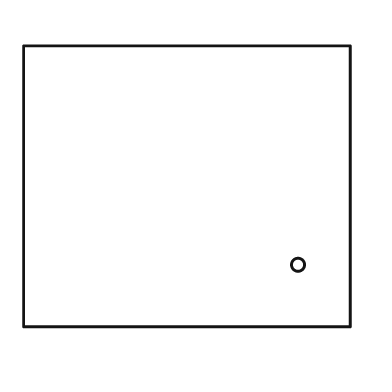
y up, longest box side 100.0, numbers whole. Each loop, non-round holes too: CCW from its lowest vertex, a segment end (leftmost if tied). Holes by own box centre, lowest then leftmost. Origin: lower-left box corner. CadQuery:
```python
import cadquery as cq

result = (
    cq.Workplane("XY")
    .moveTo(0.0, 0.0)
    .lineTo(100.0, 0.0)
    .lineTo(100.0, 86.0)
    .lineTo(0.0, 86.0)
    .close()
    .moveTo(84.0, 19.0)
    .circle(2.0)
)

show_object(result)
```